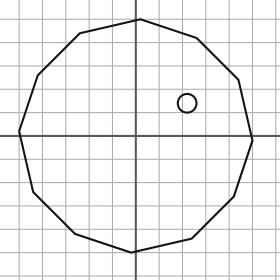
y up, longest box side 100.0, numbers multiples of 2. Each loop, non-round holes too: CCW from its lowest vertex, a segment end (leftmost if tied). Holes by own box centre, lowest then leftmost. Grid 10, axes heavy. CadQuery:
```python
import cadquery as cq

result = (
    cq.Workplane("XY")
    .moveTo(-2.0, -50.0)
    .lineTo(24.0, -44.0)
    .lineTo(42.0, -26.0)
    .lineTo(50.0, -2.0)
    .lineTo(44.0, 24.0)
    .lineTo(26.0, 42.0)
    .lineTo(2.0, 50.0)
    .lineTo(-24.0, 44.0)
    .lineTo(-42.0, 26.0)
    .lineTo(-50.0, 2.0)
    .lineTo(-44.0, -24.0)
    .lineTo(-26.0, -42.0)
    .close()
    .moveTo(22.0, 14.0)
    .circle(4.0)
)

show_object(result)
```